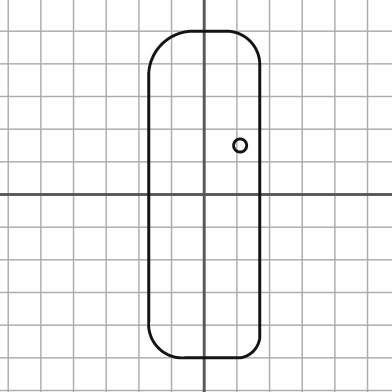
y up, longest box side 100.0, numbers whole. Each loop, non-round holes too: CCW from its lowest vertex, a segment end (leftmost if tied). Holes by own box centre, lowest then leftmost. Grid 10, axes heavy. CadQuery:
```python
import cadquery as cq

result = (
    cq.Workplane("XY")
    .moveTo(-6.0, -50.0)
    .lineTo(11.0, -50.0)
    .threePointArc((15.0, -48.0), (17.0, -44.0))
    .lineTo(17.0, 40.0)
    .threePointArc((14.0, 47.0), (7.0, 50.0))
    .lineTo(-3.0, 50.0)
    .threePointArc((-13.0, 46.0), (-17.0, 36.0))
    .lineTo(-17.0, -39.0)
    .threePointArc((-14.0, -47.0), (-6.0, -50.0))
    .close()
    .moveTo(11.0, 15.0)
    .circle(2.0)
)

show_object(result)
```